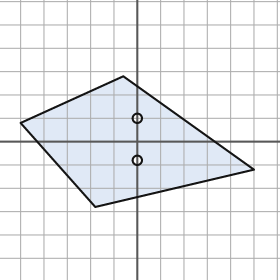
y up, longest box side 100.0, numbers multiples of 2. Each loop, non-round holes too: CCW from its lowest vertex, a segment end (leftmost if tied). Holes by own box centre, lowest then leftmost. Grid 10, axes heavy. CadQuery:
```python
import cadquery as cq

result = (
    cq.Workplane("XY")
    .moveTo(-18.0, -28.0)
    .lineTo(50.0, -12.0)
    .lineTo(-6.0, 28.0)
    .lineTo(-50.0, 8.0)
    .close()
    .moveTo(0.0, -8.0)
    .circle(2.0)
    .moveTo(0.0, 10.0)
    .circle(2.0)
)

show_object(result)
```